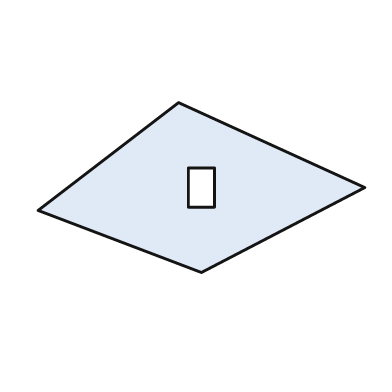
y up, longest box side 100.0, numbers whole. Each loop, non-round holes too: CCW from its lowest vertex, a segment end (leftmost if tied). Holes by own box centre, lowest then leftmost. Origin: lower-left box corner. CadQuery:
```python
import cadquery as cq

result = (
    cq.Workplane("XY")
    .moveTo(50.0, 0.0)
    .lineTo(100.0, 26.0)
    .lineTo(43.0, 52.0)
    .lineTo(0.0, 19.0)
    .close()
    .moveTo(46.0, 20.0)
    .lineTo(54.0, 20.0)
    .lineTo(54.0, 32.0)
    .lineTo(46.0, 32.0)
    .close()
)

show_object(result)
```